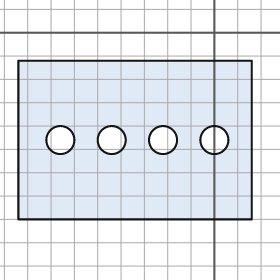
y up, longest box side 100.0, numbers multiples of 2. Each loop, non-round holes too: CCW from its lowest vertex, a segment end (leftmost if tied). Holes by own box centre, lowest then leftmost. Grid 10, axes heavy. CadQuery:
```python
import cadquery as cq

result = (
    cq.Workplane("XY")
    .moveTo(-84.0, -80.0)
    .lineTo(16.0, -80.0)
    .lineTo(16.0, -12.0)
    .lineTo(-84.0, -12.0)
    .close()
    .moveTo(-66.0, -46.0)
    .circle(6.0)
    .moveTo(-44.0, -46.0)
    .circle(6.0)
    .moveTo(-22.0, -46.0)
    .circle(6.0)
    .moveTo(0.0, -46.0)
    .circle(6.0)
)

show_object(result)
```